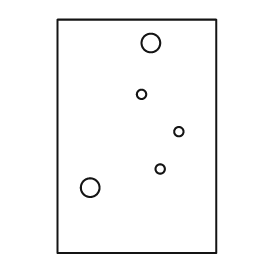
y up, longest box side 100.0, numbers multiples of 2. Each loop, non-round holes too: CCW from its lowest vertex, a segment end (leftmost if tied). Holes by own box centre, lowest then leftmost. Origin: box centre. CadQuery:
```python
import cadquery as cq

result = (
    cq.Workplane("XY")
    .moveTo(-34.0, -50.0)
    .lineTo(34.0, -50.0)
    .lineTo(34.0, 50.0)
    .lineTo(-34.0, 50.0)
    .close()
    .moveTo(-20.0, -22.0)
    .circle(4.0)
    .moveTo(10.0, -14.0)
    .circle(2.0)
    .moveTo(18.0, 2.0)
    .circle(2.0)
    .moveTo(2.0, 18.0)
    .circle(2.0)
    .moveTo(6.0, 40.0)
    .circle(4.0)
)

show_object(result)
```